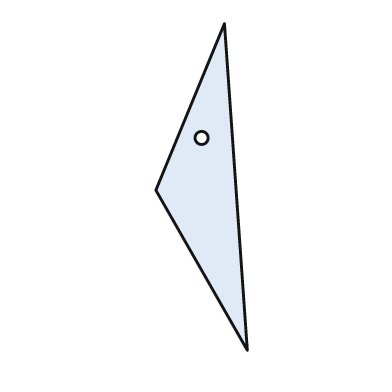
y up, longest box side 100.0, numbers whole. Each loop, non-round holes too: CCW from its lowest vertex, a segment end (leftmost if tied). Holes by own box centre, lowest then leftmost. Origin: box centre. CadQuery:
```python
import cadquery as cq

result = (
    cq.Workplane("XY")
    .moveTo(14.0, -50.0)
    .lineTo(7.0, 50.0)
    .lineTo(-14.0, -1.0)
    .close()
    .moveTo(0.0, 15.0)
    .circle(2.0)
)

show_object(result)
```